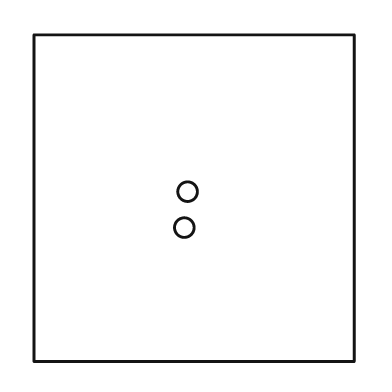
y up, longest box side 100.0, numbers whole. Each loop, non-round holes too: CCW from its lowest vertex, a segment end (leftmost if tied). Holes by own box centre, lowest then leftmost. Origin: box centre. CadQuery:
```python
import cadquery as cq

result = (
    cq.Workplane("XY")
    .moveTo(-49.0, -50.0)
    .lineTo(49.0, -50.0)
    .lineTo(49.0, 50.0)
    .lineTo(-49.0, 50.0)
    .close()
    .moveTo(-3.0, -9.0)
    .circle(3.0)
    .moveTo(-2.0, 2.0)
    .circle(3.0)
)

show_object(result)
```